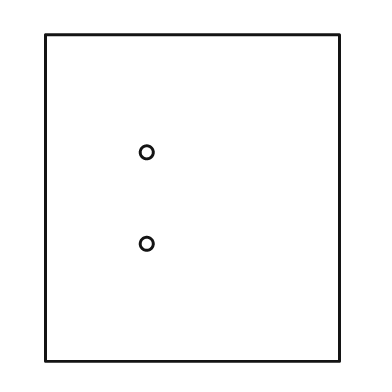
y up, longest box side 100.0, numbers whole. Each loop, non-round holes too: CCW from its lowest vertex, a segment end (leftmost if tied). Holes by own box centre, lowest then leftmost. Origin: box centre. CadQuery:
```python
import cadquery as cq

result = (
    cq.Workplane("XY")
    .moveTo(-45.0, -50.0)
    .lineTo(45.0, -50.0)
    .lineTo(45.0, 50.0)
    .lineTo(-45.0, 50.0)
    .close()
    .moveTo(-14.0, -14.0)
    .circle(2.0)
    .moveTo(-14.0, 14.0)
    .circle(2.0)
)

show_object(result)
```